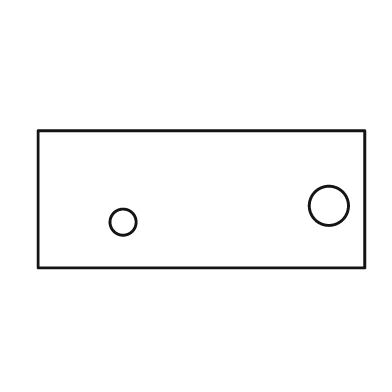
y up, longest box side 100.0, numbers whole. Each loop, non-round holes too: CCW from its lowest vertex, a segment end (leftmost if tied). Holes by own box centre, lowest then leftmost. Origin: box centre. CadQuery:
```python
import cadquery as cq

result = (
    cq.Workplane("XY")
    .moveTo(-50.0, -21.0)
    .lineTo(50.0, -21.0)
    .lineTo(50.0, 21.0)
    .lineTo(-50.0, 21.0)
    .close()
    .moveTo(-24.0, -7.0)
    .circle(4.0)
    .moveTo(39.0, -2.0)
    .circle(6.0)
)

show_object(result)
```